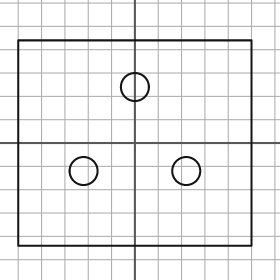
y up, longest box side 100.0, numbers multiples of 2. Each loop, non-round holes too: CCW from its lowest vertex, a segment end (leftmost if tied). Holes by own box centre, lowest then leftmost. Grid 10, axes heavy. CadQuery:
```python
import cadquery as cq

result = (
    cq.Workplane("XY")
    .moveTo(-50.0, -44.0)
    .lineTo(50.0, -44.0)
    .lineTo(50.0, 44.0)
    .lineTo(-50.0, 44.0)
    .close()
    .moveTo(-22.0, -12.0)
    .circle(6.0)
    .moveTo(22.0, -12.0)
    .circle(6.0)
    .moveTo(0.0, 24.0)
    .circle(6.0)
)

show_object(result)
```